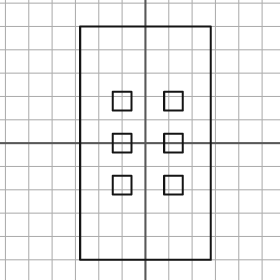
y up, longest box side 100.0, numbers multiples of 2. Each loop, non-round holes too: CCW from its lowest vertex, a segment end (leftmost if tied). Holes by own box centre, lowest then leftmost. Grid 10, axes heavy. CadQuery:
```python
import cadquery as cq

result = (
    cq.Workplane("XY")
    .moveTo(-28.0, -50.0)
    .lineTo(28.0, -50.0)
    .lineTo(28.0, 50.0)
    .lineTo(-28.0, 50.0)
    .close()
    .moveTo(-14.0, -22.0)
    .lineTo(-6.0, -22.0)
    .lineTo(-6.0, -14.0)
    .lineTo(-14.0, -14.0)
    .close()
    .moveTo(8.0, -22.0)
    .lineTo(16.0, -22.0)
    .lineTo(16.0, -14.0)
    .lineTo(8.0, -14.0)
    .close()
    .moveTo(-14.0, -4.0)
    .lineTo(-6.0, -4.0)
    .lineTo(-6.0, 4.0)
    .lineTo(-14.0, 4.0)
    .close()
    .moveTo(8.0, -4.0)
    .lineTo(16.0, -4.0)
    .lineTo(16.0, 4.0)
    .lineTo(8.0, 4.0)
    .close()
    .moveTo(-14.0, 14.0)
    .lineTo(-6.0, 14.0)
    .lineTo(-6.0, 22.0)
    .lineTo(-14.0, 22.0)
    .close()
    .moveTo(8.0, 14.0)
    .lineTo(16.0, 14.0)
    .lineTo(16.0, 22.0)
    .lineTo(8.0, 22.0)
    .close()
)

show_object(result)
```